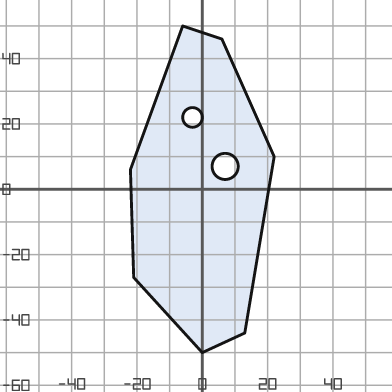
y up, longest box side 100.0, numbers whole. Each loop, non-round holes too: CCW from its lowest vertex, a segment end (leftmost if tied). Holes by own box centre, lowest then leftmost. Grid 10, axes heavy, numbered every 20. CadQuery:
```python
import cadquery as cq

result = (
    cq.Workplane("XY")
    .moveTo(0.0, -50.0)
    .lineTo(13.0, -44.0)
    .lineTo(22.0, 10.0)
    .lineTo(6.0, 46.0)
    .lineTo(-6.0, 50.0)
    .lineTo(-22.0, 6.0)
    .lineTo(-21.0, -27.0)
    .close()
    .moveTo(7.0, 7.0)
    .circle(4.0)
    .moveTo(-3.0, 22.0)
    .circle(3.0)
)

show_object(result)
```